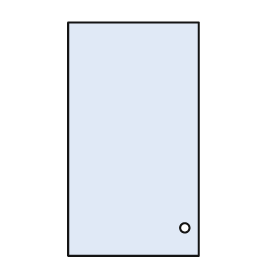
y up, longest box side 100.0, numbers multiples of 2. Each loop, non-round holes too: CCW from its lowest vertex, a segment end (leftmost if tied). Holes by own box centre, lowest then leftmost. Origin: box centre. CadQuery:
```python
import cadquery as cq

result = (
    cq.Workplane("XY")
    .moveTo(-28.0, -50.0)
    .lineTo(28.0, -50.0)
    .lineTo(28.0, 50.0)
    .lineTo(-28.0, 50.0)
    .close()
    .moveTo(22.0, -38.0)
    .circle(2.0)
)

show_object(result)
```